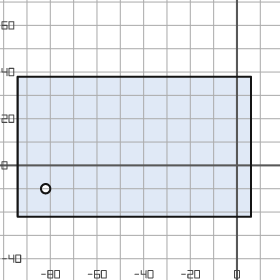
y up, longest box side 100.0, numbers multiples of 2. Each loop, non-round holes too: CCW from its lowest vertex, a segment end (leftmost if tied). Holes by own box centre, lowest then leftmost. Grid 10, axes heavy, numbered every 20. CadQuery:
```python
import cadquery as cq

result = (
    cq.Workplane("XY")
    .moveTo(-94.0, -22.0)
    .lineTo(6.0, -22.0)
    .lineTo(6.0, 38.0)
    .lineTo(-94.0, 38.0)
    .close()
    .moveTo(-82.0, -10.0)
    .circle(2.0)
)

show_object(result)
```